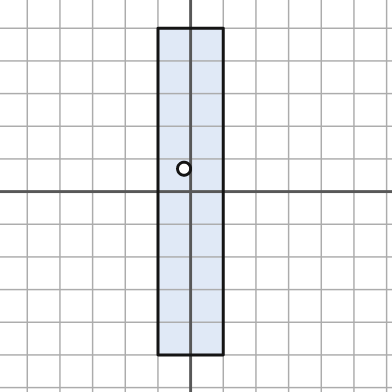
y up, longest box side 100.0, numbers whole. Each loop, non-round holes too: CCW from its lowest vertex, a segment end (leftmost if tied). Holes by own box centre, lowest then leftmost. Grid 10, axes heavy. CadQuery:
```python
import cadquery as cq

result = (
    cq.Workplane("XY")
    .moveTo(-10.0, -50.0)
    .lineTo(10.0, -50.0)
    .lineTo(10.0, 50.0)
    .lineTo(-10.0, 50.0)
    .close()
    .moveTo(-2.0, 7.0)
    .circle(2.0)
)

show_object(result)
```